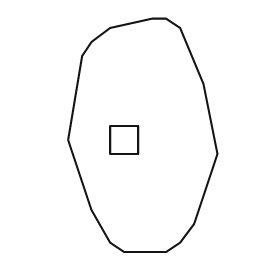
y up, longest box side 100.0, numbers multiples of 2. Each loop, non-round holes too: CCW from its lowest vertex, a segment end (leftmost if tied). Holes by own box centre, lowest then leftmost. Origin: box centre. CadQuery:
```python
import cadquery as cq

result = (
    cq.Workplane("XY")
    .moveTo(-8.0, -50.0)
    .lineTo(10.0, -50.0)
    .lineTo(16.0, -46.0)
    .lineTo(22.0, -38.0)
    .lineTo(32.0, -8.0)
    .lineTo(26.0, 22.0)
    .lineTo(16.0, 46.0)
    .lineTo(10.0, 50.0)
    .lineTo(4.0, 50.0)
    .lineTo(-14.0, 46.0)
    .lineTo(-22.0, 40.0)
    .lineTo(-26.0, 34.0)
    .lineTo(-32.0, -2.0)
    .lineTo(-22.0, -32.0)
    .lineTo(-14.0, -46.0)
    .close()
    .moveTo(-14.0, -8.0)
    .lineTo(-2.0, -8.0)
    .lineTo(-2.0, 4.0)
    .lineTo(-14.0, 4.0)
    .close()
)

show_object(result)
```